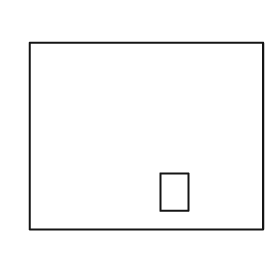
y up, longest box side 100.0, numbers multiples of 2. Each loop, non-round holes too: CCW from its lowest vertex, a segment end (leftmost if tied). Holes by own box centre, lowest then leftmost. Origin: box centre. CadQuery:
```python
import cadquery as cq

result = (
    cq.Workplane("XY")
    .moveTo(-50.0, -40.0)
    .lineTo(50.0, -40.0)
    .lineTo(50.0, 40.0)
    .lineTo(-50.0, 40.0)
    .close()
    .moveTo(6.0, -32.0)
    .lineTo(18.0, -32.0)
    .lineTo(18.0, -16.0)
    .lineTo(6.0, -16.0)
    .close()
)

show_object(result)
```